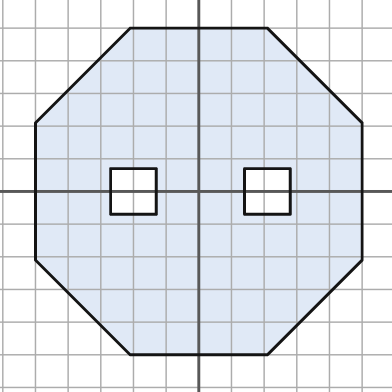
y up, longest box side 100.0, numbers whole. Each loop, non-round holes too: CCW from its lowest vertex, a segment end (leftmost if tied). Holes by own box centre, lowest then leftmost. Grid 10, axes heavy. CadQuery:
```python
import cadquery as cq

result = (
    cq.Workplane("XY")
    .moveTo(-21.0, -50.0)
    .lineTo(21.0, -50.0)
    .lineTo(50.0, -21.0)
    .lineTo(50.0, 21.0)
    .lineTo(21.0, 50.0)
    .lineTo(-21.0, 50.0)
    .lineTo(-50.0, 21.0)
    .lineTo(-50.0, -21.0)
    .close()
    .moveTo(-27.0, -7.0)
    .lineTo(-13.0, -7.0)
    .lineTo(-13.0, 7.0)
    .lineTo(-27.0, 7.0)
    .close()
    .moveTo(14.0, -7.0)
    .lineTo(28.0, -7.0)
    .lineTo(28.0, 7.0)
    .lineTo(14.0, 7.0)
    .close()
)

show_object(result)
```